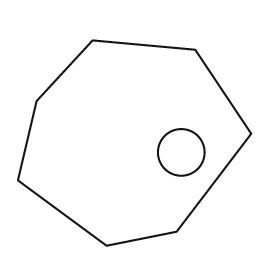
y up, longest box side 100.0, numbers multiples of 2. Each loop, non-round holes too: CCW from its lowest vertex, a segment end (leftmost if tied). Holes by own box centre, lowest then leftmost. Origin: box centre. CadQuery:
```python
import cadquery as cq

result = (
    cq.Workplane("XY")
    .moveTo(-12.0, -44.0)
    .lineTo(18.0, -38.0)
    .lineTo(50.0, 4.0)
    .lineTo(26.0, 40.0)
    .lineTo(-18.0, 44.0)
    .lineTo(-42.0, 18.0)
    .lineTo(-50.0, -16.0)
    .close()
    .moveTo(20.0, -4.0)
    .circle(10.0)
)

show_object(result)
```